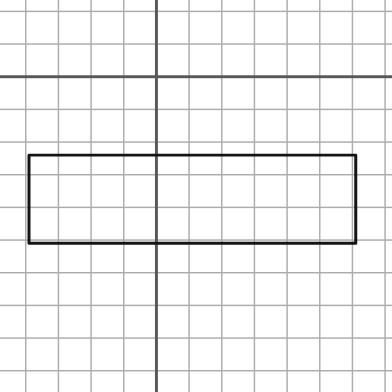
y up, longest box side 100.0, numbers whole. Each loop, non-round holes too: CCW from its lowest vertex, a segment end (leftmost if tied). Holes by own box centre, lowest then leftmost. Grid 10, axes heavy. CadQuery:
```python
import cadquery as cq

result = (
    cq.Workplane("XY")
    .moveTo(-39.0, -51.0)
    .lineTo(61.0, -51.0)
    .lineTo(61.0, -24.0)
    .lineTo(-39.0, -24.0)
    .close()
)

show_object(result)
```